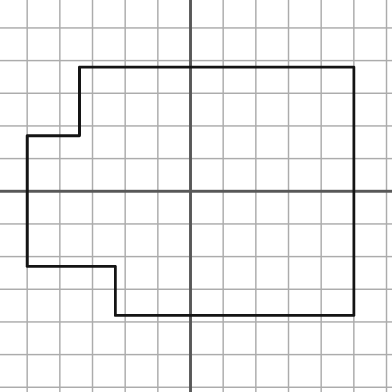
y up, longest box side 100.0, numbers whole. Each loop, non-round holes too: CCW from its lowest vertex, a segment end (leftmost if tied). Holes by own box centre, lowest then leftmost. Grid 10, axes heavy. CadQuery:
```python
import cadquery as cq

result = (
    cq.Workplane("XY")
    .moveTo(-23.0, -38.0)
    .lineTo(50.0, -38.0)
    .lineTo(50.0, 38.0)
    .lineTo(-34.0, 38.0)
    .lineTo(-34.0, 17.0)
    .lineTo(-50.0, 17.0)
    .lineTo(-50.0, -23.0)
    .lineTo(-23.0, -23.0)
    .close()
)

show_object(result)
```